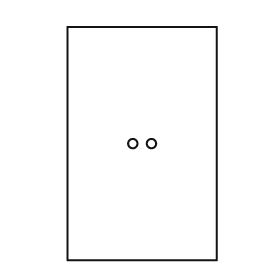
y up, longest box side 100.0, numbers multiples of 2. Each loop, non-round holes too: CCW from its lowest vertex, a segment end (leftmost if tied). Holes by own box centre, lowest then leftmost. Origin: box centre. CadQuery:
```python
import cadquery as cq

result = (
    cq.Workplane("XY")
    .moveTo(-32.0, -50.0)
    .lineTo(32.0, -50.0)
    .lineTo(32.0, 50.0)
    .lineTo(-32.0, 50.0)
    .close()
    .moveTo(-4.0, 0.0)
    .circle(2.0)
    .moveTo(4.0, 0.0)
    .circle(2.0)
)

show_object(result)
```